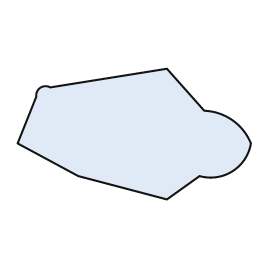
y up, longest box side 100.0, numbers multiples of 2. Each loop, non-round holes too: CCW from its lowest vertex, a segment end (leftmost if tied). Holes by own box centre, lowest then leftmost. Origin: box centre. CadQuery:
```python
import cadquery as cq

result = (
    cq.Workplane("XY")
    .moveTo(14.0, -28.0)
    .lineTo(28.0, -18.0)
    .threePointArc((42.0, -16.0), (50.0, -4.0))
    .threePointArc((42.0, 6.0), (30.0, 10.0))
    .lineTo(14.0, 28.0)
    .lineTo(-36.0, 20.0)
    .threePointArc((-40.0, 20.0), (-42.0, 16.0))
    .lineTo(-50.0, -4.0)
    .lineTo(-24.0, -18.0)
    .close()
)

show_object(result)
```